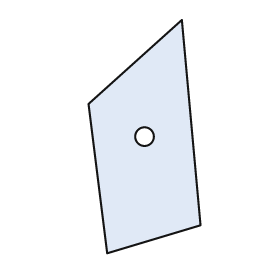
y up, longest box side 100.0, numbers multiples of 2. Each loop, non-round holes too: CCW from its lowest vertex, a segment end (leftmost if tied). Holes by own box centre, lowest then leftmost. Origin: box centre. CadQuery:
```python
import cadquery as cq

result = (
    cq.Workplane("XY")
    .moveTo(-16.0, -50.0)
    .lineTo(24.0, -38.0)
    .lineTo(16.0, 50.0)
    .lineTo(-24.0, 14.0)
    .close()
    .moveTo(0.0, 0.0)
    .circle(4.0)
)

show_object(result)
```